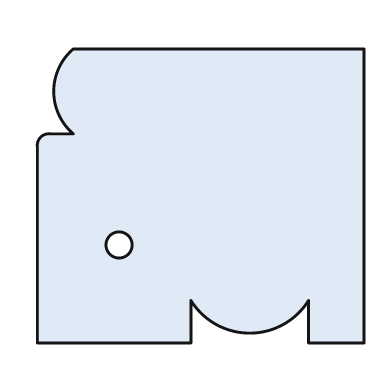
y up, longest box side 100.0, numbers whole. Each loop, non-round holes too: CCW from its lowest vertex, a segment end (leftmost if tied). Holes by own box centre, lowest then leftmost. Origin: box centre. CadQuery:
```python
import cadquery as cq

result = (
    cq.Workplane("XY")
    .moveTo(-50.0, -45.0)
    .lineTo(-3.0, -45.0)
    .lineTo(-3.0, -32.0)
    .threePointArc((15.0, -42.0), (33.0, -32.0))
    .lineTo(33.0, -45.0)
    .lineTo(50.0, -45.0)
    .lineTo(50.0, 45.0)
    .lineTo(-39.0, 45.0)
    .threePointArc((-45.0, 32.0), (-39.0, 19.0))
    .lineTo(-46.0, 19.0)
    .threePointArc((-49.0, 18.0), (-50.0, 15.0))
    .close()
    .moveTo(-25.0, -15.0)
    .circle(4.0)
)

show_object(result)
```